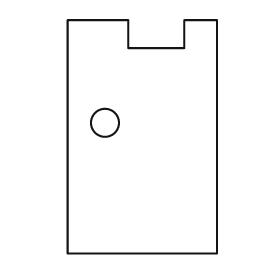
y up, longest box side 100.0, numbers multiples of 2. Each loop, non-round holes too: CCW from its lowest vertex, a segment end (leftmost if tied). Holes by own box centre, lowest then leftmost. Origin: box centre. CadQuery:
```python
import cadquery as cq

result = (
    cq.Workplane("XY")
    .moveTo(-32.0, -50.0)
    .lineTo(32.0, -50.0)
    .lineTo(32.0, 50.0)
    .lineTo(18.0, 50.0)
    .lineTo(18.0, 38.0)
    .lineTo(-6.0, 38.0)
    .lineTo(-6.0, 50.0)
    .lineTo(-32.0, 50.0)
    .close()
    .moveTo(-16.0, 6.0)
    .circle(6.0)
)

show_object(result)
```